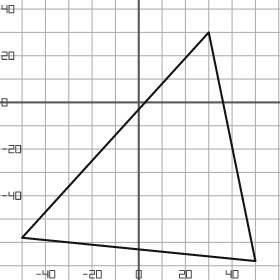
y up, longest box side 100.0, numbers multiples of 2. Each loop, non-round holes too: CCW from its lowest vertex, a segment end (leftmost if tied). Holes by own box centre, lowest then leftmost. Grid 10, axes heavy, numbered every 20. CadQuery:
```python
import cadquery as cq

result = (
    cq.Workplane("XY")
    .moveTo(50.0, -68.0)
    .lineTo(30.0, 30.0)
    .lineTo(-50.0, -58.0)
    .close()
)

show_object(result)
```